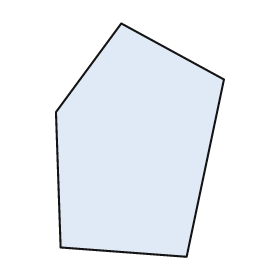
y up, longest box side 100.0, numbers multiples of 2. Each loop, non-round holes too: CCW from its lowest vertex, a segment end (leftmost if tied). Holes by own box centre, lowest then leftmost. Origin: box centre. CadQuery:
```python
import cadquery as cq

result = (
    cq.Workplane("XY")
    .moveTo(20.0, -50.0)
    .lineTo(36.0, 26.0)
    .lineTo(-8.0, 50.0)
    .lineTo(-36.0, 12.0)
    .lineTo(-34.0, -46.0)
    .close()
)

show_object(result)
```